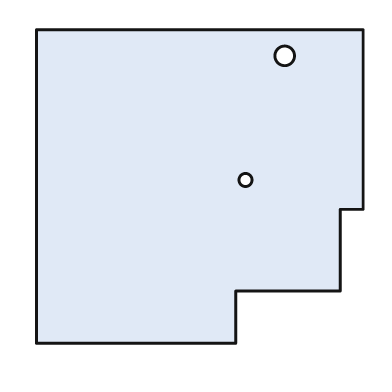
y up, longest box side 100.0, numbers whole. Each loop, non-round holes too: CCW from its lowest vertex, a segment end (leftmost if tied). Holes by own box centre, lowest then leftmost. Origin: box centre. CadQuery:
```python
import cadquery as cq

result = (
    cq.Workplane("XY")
    .moveTo(-50.0, -48.0)
    .lineTo(11.0, -48.0)
    .lineTo(11.0, -32.0)
    .lineTo(43.0, -32.0)
    .lineTo(43.0, -7.0)
    .lineTo(50.0, -7.0)
    .lineTo(50.0, 48.0)
    .lineTo(-50.0, 48.0)
    .close()
    .moveTo(14.0, 2.0)
    .circle(2.0)
    .moveTo(26.0, 40.0)
    .circle(3.0)
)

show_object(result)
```